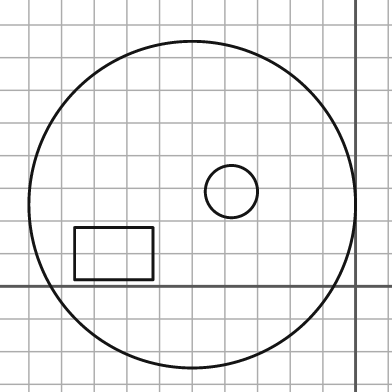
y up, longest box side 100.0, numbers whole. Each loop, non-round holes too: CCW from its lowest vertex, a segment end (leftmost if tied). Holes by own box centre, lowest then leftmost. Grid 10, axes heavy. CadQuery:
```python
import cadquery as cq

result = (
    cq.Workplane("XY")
    .moveTo(-50.0, 25.0)
    .circle(50.0)
    .moveTo(-86.0, 2.0)
    .lineTo(-62.0, 2.0)
    .lineTo(-62.0, 18.0)
    .lineTo(-86.0, 18.0)
    .close()
    .moveTo(-38.0, 29.0)
    .circle(8.0)
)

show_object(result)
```